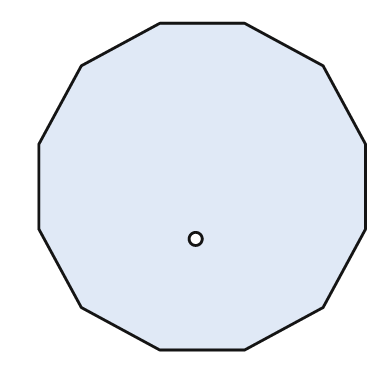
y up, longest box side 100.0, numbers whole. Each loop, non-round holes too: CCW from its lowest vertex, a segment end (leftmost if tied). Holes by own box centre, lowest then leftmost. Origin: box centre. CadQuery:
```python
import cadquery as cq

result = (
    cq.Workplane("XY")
    .moveTo(-13.0, -50.0)
    .lineTo(13.0, -50.0)
    .lineTo(37.0, -37.0)
    .lineTo(50.0, -13.0)
    .lineTo(50.0, 13.0)
    .lineTo(37.0, 37.0)
    .lineTo(13.0, 50.0)
    .lineTo(-13.0, 50.0)
    .lineTo(-37.0, 37.0)
    .lineTo(-50.0, 13.0)
    .lineTo(-50.0, -13.0)
    .lineTo(-37.0, -37.0)
    .close()
    .moveTo(-2.0, -16.0)
    .circle(2.0)
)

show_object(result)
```